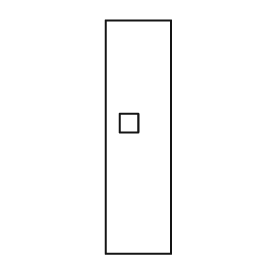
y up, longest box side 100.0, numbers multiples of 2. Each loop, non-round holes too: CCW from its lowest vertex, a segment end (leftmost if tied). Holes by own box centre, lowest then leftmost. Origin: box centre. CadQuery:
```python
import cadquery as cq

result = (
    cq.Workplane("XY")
    .moveTo(-14.0, -50.0)
    .lineTo(14.0, -50.0)
    .lineTo(14.0, 50.0)
    .lineTo(-14.0, 50.0)
    .close()
    .moveTo(-8.0, 2.0)
    .lineTo(0.0, 2.0)
    .lineTo(0.0, 10.0)
    .lineTo(-8.0, 10.0)
    .close()
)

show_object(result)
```